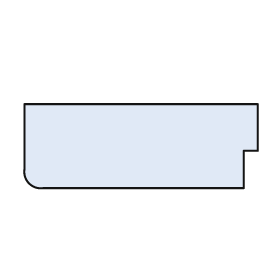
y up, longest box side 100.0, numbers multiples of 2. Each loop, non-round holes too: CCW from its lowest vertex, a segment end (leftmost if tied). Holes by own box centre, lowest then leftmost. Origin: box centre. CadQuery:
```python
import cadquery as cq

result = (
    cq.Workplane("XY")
    .moveTo(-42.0, -18.0)
    .lineTo(44.0, -18.0)
    .lineTo(44.0, -2.0)
    .lineTo(50.0, -2.0)
    .lineTo(50.0, 18.0)
    .lineTo(-50.0, 18.0)
    .lineTo(-50.0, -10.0)
    .threePointArc((-48.0, -16.0), (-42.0, -18.0))
    .close()
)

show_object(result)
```